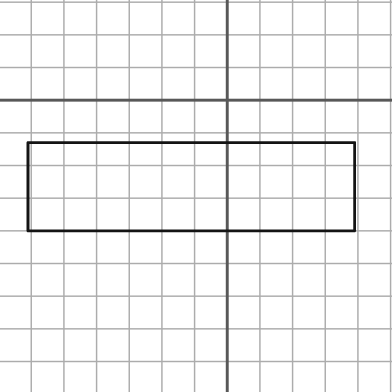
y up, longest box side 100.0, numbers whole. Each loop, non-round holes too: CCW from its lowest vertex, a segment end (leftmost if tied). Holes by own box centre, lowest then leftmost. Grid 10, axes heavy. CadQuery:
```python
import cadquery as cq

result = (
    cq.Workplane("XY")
    .moveTo(-61.0, -40.0)
    .lineTo(39.0, -40.0)
    .lineTo(39.0, -13.0)
    .lineTo(-61.0, -13.0)
    .close()
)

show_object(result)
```